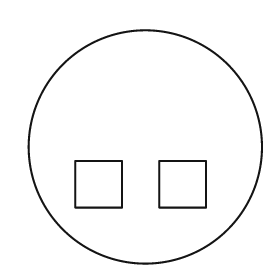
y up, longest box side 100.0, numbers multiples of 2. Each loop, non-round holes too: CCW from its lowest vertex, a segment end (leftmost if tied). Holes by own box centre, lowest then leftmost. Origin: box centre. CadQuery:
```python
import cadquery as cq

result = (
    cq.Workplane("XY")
    .moveTo(0.0, 0.0)
    .circle(50.0)
    .moveTo(-30.0, -26.0)
    .lineTo(-10.0, -26.0)
    .lineTo(-10.0, -6.0)
    .lineTo(-30.0, -6.0)
    .close()
    .moveTo(6.0, -26.0)
    .lineTo(26.0, -26.0)
    .lineTo(26.0, -6.0)
    .lineTo(6.0, -6.0)
    .close()
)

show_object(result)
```